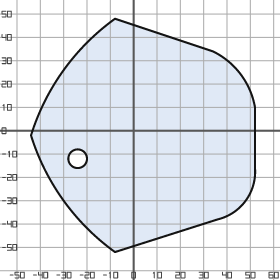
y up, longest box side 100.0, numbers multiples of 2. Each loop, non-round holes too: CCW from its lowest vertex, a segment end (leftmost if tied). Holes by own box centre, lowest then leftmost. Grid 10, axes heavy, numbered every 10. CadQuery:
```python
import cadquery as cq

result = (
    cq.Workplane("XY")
    .moveTo(-8.0, -52.0)
    .lineTo(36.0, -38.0)
    .threePointArc((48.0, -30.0), (52.0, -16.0))
    .lineTo(52.0, 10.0)
    .threePointArc((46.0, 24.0), (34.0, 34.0))
    .lineTo(-8.0, 48.0)
    .threePointArc((-30.0, 26.0), (-44.0, -2.0))
    .threePointArc((-30.0, -30.0), (-8.0, -52.0))
    .close()
    .moveTo(-24.0, -12.0)
    .circle(4.0)
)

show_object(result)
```